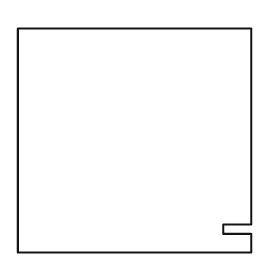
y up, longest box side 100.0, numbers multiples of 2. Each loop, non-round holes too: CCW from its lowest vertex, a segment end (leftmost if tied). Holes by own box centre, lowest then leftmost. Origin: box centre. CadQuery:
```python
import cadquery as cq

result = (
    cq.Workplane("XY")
    .moveTo(-50.0, -48.0)
    .lineTo(50.0, -48.0)
    .lineTo(50.0, -40.0)
    .lineTo(38.0, -40.0)
    .lineTo(38.0, -36.0)
    .lineTo(50.0, -36.0)
    .lineTo(50.0, 48.0)
    .lineTo(-50.0, 48.0)
    .close()
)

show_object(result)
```